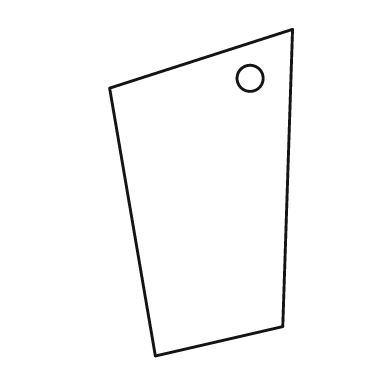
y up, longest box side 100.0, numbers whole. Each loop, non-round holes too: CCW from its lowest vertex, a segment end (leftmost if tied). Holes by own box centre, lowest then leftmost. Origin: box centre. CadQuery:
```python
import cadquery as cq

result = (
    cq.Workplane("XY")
    .moveTo(-14.0, -50.0)
    .lineTo(25.0, -41.0)
    .lineTo(28.0, 50.0)
    .lineTo(-28.0, 32.0)
    .close()
    .moveTo(15.0, 35.0)
    .circle(4.0)
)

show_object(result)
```